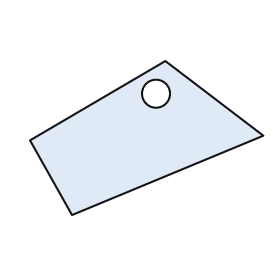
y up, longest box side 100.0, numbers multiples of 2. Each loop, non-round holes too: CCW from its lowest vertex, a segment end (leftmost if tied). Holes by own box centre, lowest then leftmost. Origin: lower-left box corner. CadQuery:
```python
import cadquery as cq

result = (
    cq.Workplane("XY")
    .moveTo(18.0, 0.0)
    .lineTo(100.0, 34.0)
    .lineTo(58.0, 66.0)
    .lineTo(0.0, 32.0)
    .close()
    .moveTo(54.0, 52.0)
    .circle(6.0)
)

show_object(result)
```